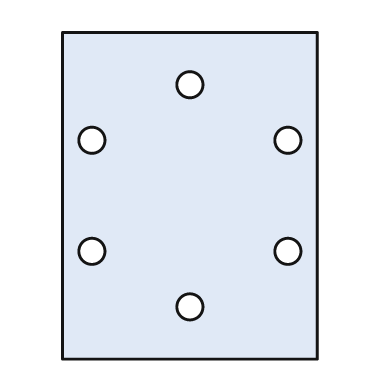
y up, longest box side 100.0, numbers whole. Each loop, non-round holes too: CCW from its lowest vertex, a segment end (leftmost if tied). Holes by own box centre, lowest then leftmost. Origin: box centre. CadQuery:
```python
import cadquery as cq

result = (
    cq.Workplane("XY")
    .moveTo(-39.0, -50.0)
    .lineTo(39.0, -50.0)
    .lineTo(39.0, 50.0)
    .lineTo(-39.0, 50.0)
    .close()
    .moveTo(0.0, -34.0)
    .circle(4.0)
    .moveTo(-30.0, -17.0)
    .circle(4.0)
    .moveTo(30.0, -17.0)
    .circle(4.0)
    .moveTo(-30.0, 17.0)
    .circle(4.0)
    .moveTo(30.0, 17.0)
    .circle(4.0)
    .moveTo(0.0, 34.0)
    .circle(4.0)
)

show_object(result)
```